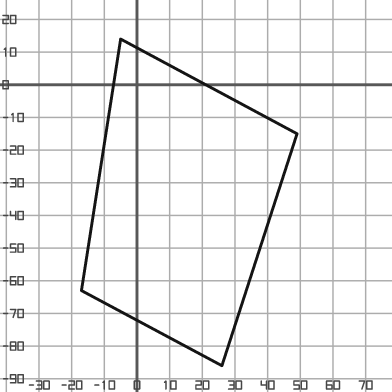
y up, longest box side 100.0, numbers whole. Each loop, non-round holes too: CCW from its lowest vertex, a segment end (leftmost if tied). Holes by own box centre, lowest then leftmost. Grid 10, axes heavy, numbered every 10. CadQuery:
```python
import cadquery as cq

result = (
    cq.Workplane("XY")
    .moveTo(26.0, -86.0)
    .lineTo(49.0, -15.0)
    .lineTo(-5.0, 14.0)
    .lineTo(-17.0, -63.0)
    .close()
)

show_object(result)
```